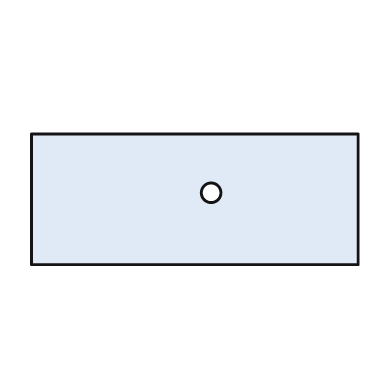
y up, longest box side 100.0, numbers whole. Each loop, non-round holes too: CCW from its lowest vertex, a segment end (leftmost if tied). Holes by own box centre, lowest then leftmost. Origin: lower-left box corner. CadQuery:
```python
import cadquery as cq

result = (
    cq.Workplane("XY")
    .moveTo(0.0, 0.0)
    .lineTo(100.0, 0.0)
    .lineTo(100.0, 40.0)
    .lineTo(0.0, 40.0)
    .close()
    .moveTo(55.0, 22.0)
    .circle(3.0)
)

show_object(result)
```